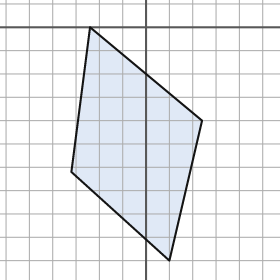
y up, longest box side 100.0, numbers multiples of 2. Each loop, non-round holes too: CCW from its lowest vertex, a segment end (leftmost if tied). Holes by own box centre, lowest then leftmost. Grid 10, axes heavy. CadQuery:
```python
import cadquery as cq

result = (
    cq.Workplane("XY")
    .moveTo(10.0, -100.0)
    .lineTo(24.0, -40.0)
    .lineTo(-24.0, 0.0)
    .lineTo(-32.0, -62.0)
    .close()
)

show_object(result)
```